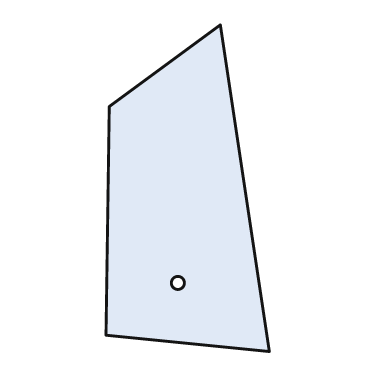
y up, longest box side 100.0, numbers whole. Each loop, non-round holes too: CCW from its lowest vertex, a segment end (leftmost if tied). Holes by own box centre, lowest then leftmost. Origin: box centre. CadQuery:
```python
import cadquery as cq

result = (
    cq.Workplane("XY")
    .moveTo(25.0, -50.0)
    .lineTo(10.0, 50.0)
    .lineTo(-24.0, 25.0)
    .lineTo(-25.0, -45.0)
    .close()
    .moveTo(-3.0, -29.0)
    .circle(2.0)
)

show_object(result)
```